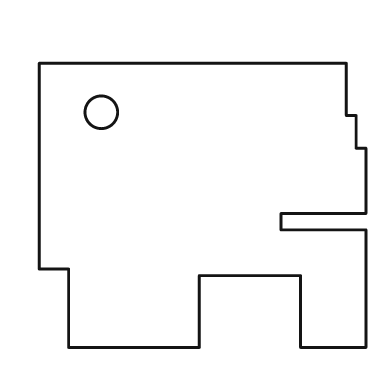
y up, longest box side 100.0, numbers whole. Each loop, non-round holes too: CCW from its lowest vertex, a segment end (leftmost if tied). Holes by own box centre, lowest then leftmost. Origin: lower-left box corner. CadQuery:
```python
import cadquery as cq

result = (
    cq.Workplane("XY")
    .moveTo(9.0, 0.0)
    .lineTo(49.0, 0.0)
    .lineTo(49.0, 22.0)
    .lineTo(80.0, 22.0)
    .lineTo(80.0, 0.0)
    .lineTo(100.0, 0.0)
    .lineTo(100.0, 36.0)
    .lineTo(74.0, 36.0)
    .lineTo(74.0, 41.0)
    .lineTo(100.0, 41.0)
    .lineTo(100.0, 61.0)
    .lineTo(97.0, 61.0)
    .lineTo(97.0, 71.0)
    .lineTo(94.0, 71.0)
    .lineTo(94.0, 87.0)
    .lineTo(0.0, 87.0)
    .lineTo(0.0, 24.0)
    .lineTo(9.0, 24.0)
    .close()
    .moveTo(19.0, 72.0)
    .circle(5.0)
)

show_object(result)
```